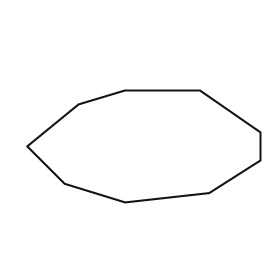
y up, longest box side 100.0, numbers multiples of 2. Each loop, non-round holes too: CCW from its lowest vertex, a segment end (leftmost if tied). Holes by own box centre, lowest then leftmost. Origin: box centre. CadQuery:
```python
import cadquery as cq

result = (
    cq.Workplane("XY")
    .moveTo(-8.0, -24.0)
    .lineTo(28.0, -20.0)
    .lineTo(50.0, -6.0)
    .lineTo(50.0, 6.0)
    .lineTo(24.0, 24.0)
    .lineTo(-8.0, 24.0)
    .lineTo(-28.0, 18.0)
    .lineTo(-50.0, 0.0)
    .lineTo(-34.0, -16.0)
    .close()
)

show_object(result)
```